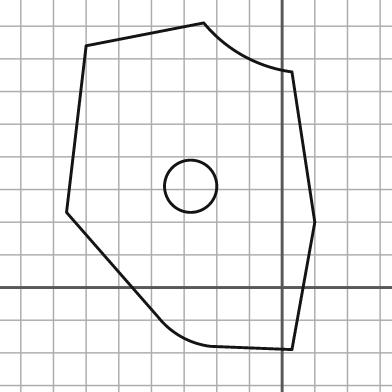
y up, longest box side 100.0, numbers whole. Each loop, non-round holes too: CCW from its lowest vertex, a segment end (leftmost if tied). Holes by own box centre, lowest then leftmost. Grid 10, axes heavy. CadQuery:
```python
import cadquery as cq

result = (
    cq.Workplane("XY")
    .moveTo(3.0, -19.0)
    .lineTo(10.0, 20.0)
    .lineTo(3.0, 66.0)
    .threePointArc((-12.0, 71.0), (-24.0, 81.0))
    .lineTo(-60.0, 74.0)
    .lineTo(-66.0, 23.0)
    .lineTo(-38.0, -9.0)
    .threePointArc((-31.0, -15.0), (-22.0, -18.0))
    .close()
    .moveTo(-28.0, 31.0)
    .circle(8.0)
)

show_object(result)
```